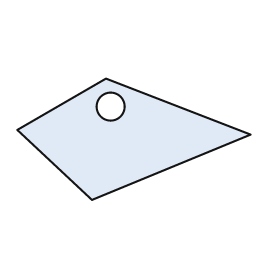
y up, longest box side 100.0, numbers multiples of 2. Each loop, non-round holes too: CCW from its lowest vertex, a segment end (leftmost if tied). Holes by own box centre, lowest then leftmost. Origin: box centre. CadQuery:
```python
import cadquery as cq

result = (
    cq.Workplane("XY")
    .moveTo(-18.0, -26.0)
    .lineTo(50.0, 2.0)
    .lineTo(-12.0, 26.0)
    .lineTo(-50.0, 4.0)
    .close()
    .moveTo(-10.0, 14.0)
    .circle(6.0)
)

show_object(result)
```